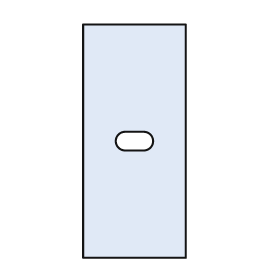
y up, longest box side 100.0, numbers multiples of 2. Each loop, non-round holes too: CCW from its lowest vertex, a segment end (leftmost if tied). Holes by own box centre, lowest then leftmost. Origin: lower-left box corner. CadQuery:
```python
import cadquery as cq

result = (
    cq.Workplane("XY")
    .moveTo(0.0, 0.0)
    .lineTo(44.0, 0.0)
    .lineTo(44.0, 100.0)
    .lineTo(0.0, 100.0)
    .close()
    .moveTo(18.0, 46.0)
    .lineTo(26.0, 46.0)
    .threePointArc((30.0, 50.0), (26.0, 54.0))
    .lineTo(18.0, 54.0)
    .threePointArc((14.0, 50.0), (18.0, 46.0))
    .close()
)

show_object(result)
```